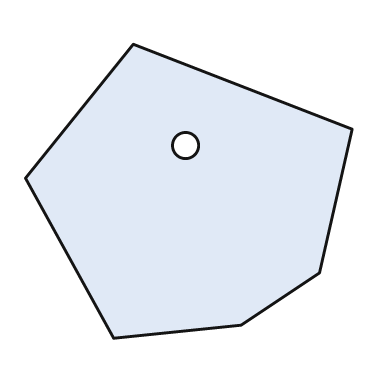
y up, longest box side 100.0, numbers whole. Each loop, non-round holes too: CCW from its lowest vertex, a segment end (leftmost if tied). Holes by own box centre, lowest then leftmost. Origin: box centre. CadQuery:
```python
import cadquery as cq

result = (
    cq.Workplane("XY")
    .moveTo(-23.0, -45.0)
    .lineTo(16.0, -41.0)
    .lineTo(40.0, -25.0)
    .lineTo(50.0, 19.0)
    .lineTo(-17.0, 45.0)
    .lineTo(-50.0, 4.0)
    .close()
    .moveTo(-1.0, 14.0)
    .circle(4.0)
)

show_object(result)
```